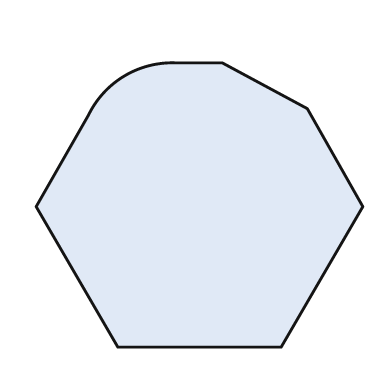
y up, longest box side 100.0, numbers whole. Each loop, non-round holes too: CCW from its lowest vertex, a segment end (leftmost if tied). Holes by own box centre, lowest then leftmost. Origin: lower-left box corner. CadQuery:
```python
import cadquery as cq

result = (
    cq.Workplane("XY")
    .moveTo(25.0, 0.0)
    .lineTo(75.0, 0.0)
    .lineTo(100.0, 43.0)
    .lineTo(83.0, 73.0)
    .lineTo(57.0, 87.0)
    .lineTo(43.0, 87.0)
    .threePointArc((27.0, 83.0), (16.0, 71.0))
    .lineTo(0.0, 43.0)
    .close()
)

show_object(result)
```